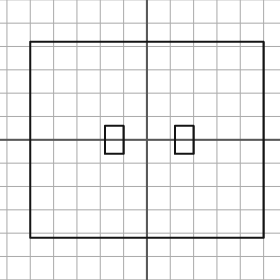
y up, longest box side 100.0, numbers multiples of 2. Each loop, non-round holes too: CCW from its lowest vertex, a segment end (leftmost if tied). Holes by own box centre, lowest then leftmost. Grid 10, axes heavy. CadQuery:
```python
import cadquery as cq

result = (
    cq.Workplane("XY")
    .moveTo(-50.0, -42.0)
    .lineTo(50.0, -42.0)
    .lineTo(50.0, 42.0)
    .lineTo(-50.0, 42.0)
    .close()
    .moveTo(-18.0, -6.0)
    .lineTo(-10.0, -6.0)
    .lineTo(-10.0, 6.0)
    .lineTo(-18.0, 6.0)
    .close()
    .moveTo(12.0, -6.0)
    .lineTo(20.0, -6.0)
    .lineTo(20.0, 6.0)
    .lineTo(12.0, 6.0)
    .close()
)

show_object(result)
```